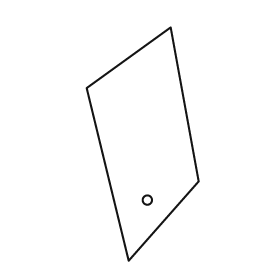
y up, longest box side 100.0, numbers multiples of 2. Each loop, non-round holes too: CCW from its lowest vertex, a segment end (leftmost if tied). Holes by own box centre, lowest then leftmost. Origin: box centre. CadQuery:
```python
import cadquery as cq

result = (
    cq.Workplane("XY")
    .moveTo(-6.0, -50.0)
    .lineTo(24.0, -16.0)
    .lineTo(12.0, 50.0)
    .lineTo(-24.0, 24.0)
    .close()
    .moveTo(2.0, -24.0)
    .circle(2.0)
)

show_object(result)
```